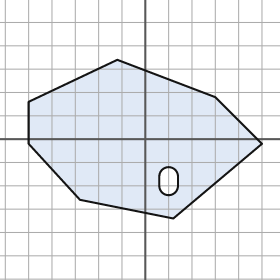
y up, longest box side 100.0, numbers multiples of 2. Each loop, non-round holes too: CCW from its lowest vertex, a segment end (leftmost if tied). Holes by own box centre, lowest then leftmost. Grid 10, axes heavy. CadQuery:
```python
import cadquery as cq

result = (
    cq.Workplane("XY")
    .moveTo(12.0, -34.0)
    .lineTo(50.0, -2.0)
    .lineTo(30.0, 18.0)
    .lineTo(-12.0, 34.0)
    .lineTo(-50.0, 16.0)
    .lineTo(-50.0, -2.0)
    .lineTo(-28.0, -26.0)
    .close()
    .moveTo(6.0, -20.0)
    .threePointArc((10.0, -24.0), (14.0, -20.0))
    .lineTo(14.0, -16.0)
    .threePointArc((10.0, -12.0), (6.0, -16.0))
    .close()
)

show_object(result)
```